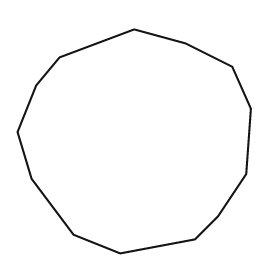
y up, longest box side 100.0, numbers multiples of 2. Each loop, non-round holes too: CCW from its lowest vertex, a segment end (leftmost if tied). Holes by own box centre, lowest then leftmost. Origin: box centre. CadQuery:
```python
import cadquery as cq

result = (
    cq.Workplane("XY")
    .moveTo(-6.0, -48.0)
    .lineTo(26.0, -42.0)
    .lineTo(36.0, -32.0)
    .lineTo(48.0, -14.0)
    .lineTo(50.0, 14.0)
    .lineTo(42.0, 32.0)
    .lineTo(22.0, 42.0)
    .lineTo(0.0, 48.0)
    .lineTo(-32.0, 36.0)
    .lineTo(-42.0, 24.0)
    .lineTo(-50.0, 4.0)
    .lineTo(-44.0, -16.0)
    .lineTo(-26.0, -40.0)
    .close()
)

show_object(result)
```